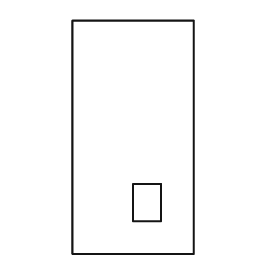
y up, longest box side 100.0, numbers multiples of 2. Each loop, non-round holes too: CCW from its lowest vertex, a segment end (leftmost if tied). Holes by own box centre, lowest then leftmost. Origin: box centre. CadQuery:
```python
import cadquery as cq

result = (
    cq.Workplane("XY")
    .moveTo(-26.0, -50.0)
    .lineTo(26.0, -50.0)
    .lineTo(26.0, 50.0)
    .lineTo(-26.0, 50.0)
    .close()
    .moveTo(0.0, -36.0)
    .lineTo(12.0, -36.0)
    .lineTo(12.0, -20.0)
    .lineTo(0.0, -20.0)
    .close()
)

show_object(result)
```